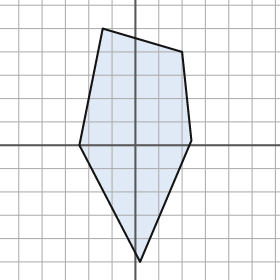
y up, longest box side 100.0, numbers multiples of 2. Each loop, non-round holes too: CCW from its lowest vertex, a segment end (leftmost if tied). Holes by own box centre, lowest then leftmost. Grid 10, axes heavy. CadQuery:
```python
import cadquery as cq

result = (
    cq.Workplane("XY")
    .moveTo(2.0, -50.0)
    .lineTo(24.0, 2.0)
    .lineTo(20.0, 40.0)
    .lineTo(-14.0, 50.0)
    .lineTo(-24.0, 0.0)
    .close()
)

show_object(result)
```